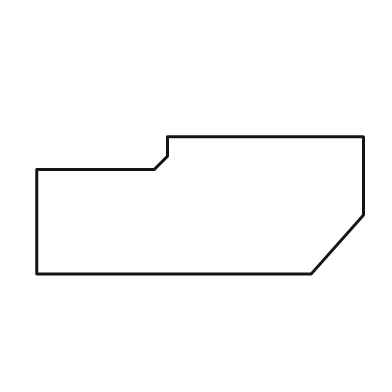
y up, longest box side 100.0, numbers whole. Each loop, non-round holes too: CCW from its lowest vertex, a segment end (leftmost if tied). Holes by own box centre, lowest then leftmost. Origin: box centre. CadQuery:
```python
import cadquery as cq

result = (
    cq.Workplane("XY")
    .moveTo(-50.0, -21.0)
    .lineTo(34.0, -21.0)
    .lineTo(50.0, -3.0)
    .lineTo(50.0, 21.0)
    .lineTo(-10.0, 21.0)
    .lineTo(-10.0, 15.0)
    .lineTo(-14.0, 11.0)
    .lineTo(-50.0, 11.0)
    .close()
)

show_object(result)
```